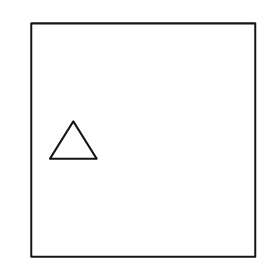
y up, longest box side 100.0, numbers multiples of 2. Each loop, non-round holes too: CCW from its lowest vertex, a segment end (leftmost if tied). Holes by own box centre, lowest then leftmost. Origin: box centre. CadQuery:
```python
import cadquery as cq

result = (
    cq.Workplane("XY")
    .moveTo(-48.0, -50.0)
    .lineTo(48.0, -50.0)
    .lineTo(48.0, 50.0)
    .lineTo(-48.0, 50.0)
    .close()
    .moveTo(-40.0, -8.0)
    .lineTo(-20.0, -8.0)
    .lineTo(-30.0, 8.0)
    .close()
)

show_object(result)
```